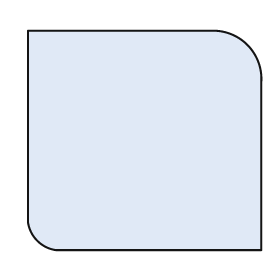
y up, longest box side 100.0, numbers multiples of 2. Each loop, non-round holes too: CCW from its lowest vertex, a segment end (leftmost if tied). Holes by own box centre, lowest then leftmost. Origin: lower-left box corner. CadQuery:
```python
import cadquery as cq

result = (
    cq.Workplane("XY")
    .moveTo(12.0, 0.0)
    .lineTo(100.0, 0.0)
    .lineTo(100.0, 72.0)
    .threePointArc((94.0, 88.0), (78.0, 94.0))
    .lineTo(0.0, 94.0)
    .lineTo(0.0, 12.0)
    .threePointArc((4.0, 4.0), (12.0, 0.0))
    .close()
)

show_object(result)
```